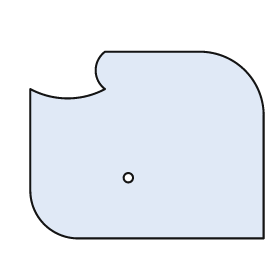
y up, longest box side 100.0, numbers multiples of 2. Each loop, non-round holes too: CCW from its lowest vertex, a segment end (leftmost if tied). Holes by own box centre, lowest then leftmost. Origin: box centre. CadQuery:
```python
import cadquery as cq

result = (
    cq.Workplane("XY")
    .moveTo(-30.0, -40.0)
    .lineTo(50.0, -40.0)
    .lineTo(50.0, 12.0)
    .threePointArc((42.0, 32.0), (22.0, 40.0))
    .lineTo(-18.0, 40.0)
    .threePointArc((-22.0, 32.0), (-18.0, 24.0))
    .threePointArc((-34.0, 20.0), (-50.0, 24.0))
    .lineTo(-50.0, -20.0)
    .threePointArc((-44.0, -34.0), (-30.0, -40.0))
    .close()
    .moveTo(-8.0, -14.0)
    .circle(2.0)
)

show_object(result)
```